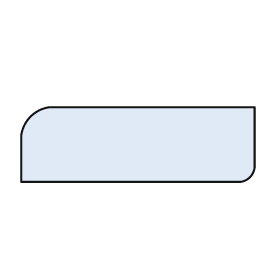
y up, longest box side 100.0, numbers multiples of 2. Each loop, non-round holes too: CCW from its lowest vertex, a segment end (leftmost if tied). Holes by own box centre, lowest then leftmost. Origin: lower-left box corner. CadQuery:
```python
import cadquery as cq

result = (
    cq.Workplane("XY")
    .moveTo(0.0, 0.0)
    .lineTo(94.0, 0.0)
    .threePointArc((98.0, 2.0), (100.0, 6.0))
    .lineTo(100.0, 32.0)
    .lineTo(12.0, 32.0)
    .threePointArc((4.0, 28.0), (0.0, 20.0))
    .close()
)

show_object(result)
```